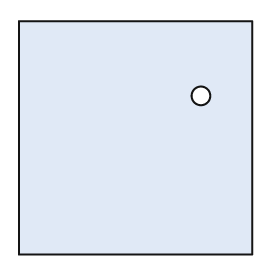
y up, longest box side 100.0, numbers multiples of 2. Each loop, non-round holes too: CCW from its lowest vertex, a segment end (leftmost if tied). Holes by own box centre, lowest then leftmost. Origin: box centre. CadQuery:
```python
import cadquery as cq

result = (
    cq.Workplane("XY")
    .moveTo(-50.0, -50.0)
    .lineTo(50.0, -50.0)
    .lineTo(50.0, 50.0)
    .lineTo(-50.0, 50.0)
    .close()
    .moveTo(28.0, 18.0)
    .circle(4.0)
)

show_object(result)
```